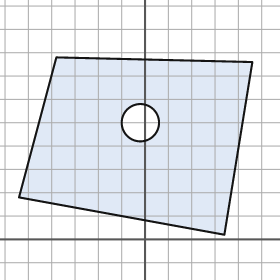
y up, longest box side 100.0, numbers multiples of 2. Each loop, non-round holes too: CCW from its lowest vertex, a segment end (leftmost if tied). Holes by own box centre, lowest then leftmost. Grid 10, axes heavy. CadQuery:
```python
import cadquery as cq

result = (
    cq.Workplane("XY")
    .moveTo(34.0, 2.0)
    .lineTo(46.0, 76.0)
    .lineTo(-38.0, 78.0)
    .lineTo(-54.0, 18.0)
    .close()
    .moveTo(-2.0, 50.0)
    .circle(8.0)
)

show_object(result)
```